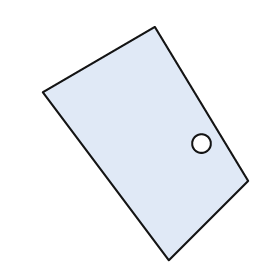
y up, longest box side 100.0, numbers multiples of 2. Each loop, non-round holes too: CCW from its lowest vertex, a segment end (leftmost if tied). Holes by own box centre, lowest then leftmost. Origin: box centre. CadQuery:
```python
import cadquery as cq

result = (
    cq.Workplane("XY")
    .moveTo(10.0, -50.0)
    .lineTo(44.0, -16.0)
    .lineTo(4.0, 50.0)
    .lineTo(-44.0, 22.0)
    .close()
    .moveTo(24.0, 0.0)
    .circle(4.0)
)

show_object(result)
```